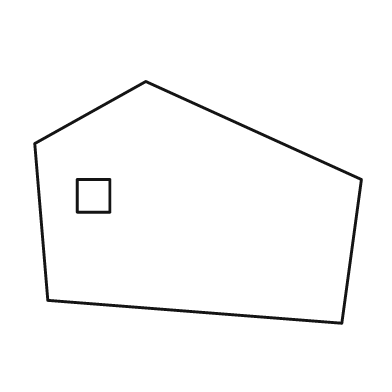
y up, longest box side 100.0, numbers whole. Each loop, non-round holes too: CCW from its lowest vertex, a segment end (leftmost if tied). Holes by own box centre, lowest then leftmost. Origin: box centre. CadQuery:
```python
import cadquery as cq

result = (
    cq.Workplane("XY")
    .moveTo(44.0, -37.0)
    .lineTo(50.0, 7.0)
    .lineTo(-16.0, 37.0)
    .lineTo(-50.0, 18.0)
    .lineTo(-46.0, -30.0)
    .close()
    .moveTo(-37.0, -3.0)
    .lineTo(-27.0, -3.0)
    .lineTo(-27.0, 7.0)
    .lineTo(-37.0, 7.0)
    .close()
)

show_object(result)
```